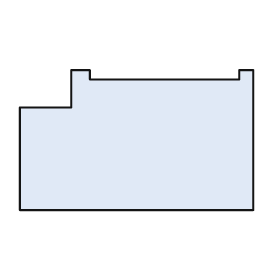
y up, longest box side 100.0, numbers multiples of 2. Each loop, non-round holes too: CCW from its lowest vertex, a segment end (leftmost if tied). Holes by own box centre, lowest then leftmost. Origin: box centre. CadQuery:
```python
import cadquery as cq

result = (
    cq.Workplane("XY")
    .moveTo(-50.0, -30.0)
    .lineTo(50.0, -30.0)
    .lineTo(50.0, 30.0)
    .lineTo(44.0, 30.0)
    .lineTo(44.0, 26.0)
    .lineTo(-20.0, 26.0)
    .lineTo(-20.0, 30.0)
    .lineTo(-28.0, 30.0)
    .lineTo(-28.0, 14.0)
    .lineTo(-50.0, 14.0)
    .close()
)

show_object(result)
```